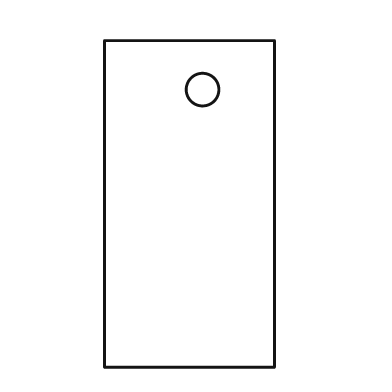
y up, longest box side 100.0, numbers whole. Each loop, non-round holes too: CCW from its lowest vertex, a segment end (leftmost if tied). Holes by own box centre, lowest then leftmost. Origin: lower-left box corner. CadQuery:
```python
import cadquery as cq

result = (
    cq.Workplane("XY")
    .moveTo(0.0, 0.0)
    .lineTo(52.0, 0.0)
    .lineTo(52.0, 100.0)
    .lineTo(0.0, 100.0)
    .close()
    .moveTo(30.0, 85.0)
    .circle(5.0)
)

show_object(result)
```